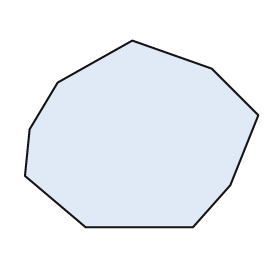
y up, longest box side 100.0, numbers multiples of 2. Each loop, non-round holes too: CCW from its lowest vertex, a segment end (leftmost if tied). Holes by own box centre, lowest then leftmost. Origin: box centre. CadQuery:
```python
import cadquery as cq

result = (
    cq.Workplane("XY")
    .moveTo(-24.0, -40.0)
    .lineTo(22.0, -40.0)
    .lineTo(38.0, -22.0)
    .lineTo(50.0, 8.0)
    .lineTo(30.0, 28.0)
    .lineTo(-4.0, 40.0)
    .lineTo(-36.0, 22.0)
    .lineTo(-48.0, 2.0)
    .lineTo(-50.0, -18.0)
    .close()
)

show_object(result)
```